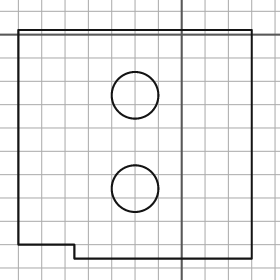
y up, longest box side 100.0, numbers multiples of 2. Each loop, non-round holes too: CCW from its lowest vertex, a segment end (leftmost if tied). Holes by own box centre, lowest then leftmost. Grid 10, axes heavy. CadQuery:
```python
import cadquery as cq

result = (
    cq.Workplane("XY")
    .moveTo(-46.0, -96.0)
    .lineTo(30.0, -96.0)
    .lineTo(30.0, 2.0)
    .lineTo(-70.0, 2.0)
    .lineTo(-70.0, -90.0)
    .lineTo(-46.0, -90.0)
    .close()
    .moveTo(-20.0, -66.0)
    .circle(10.0)
    .moveTo(-20.0, -26.0)
    .circle(10.0)
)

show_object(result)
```